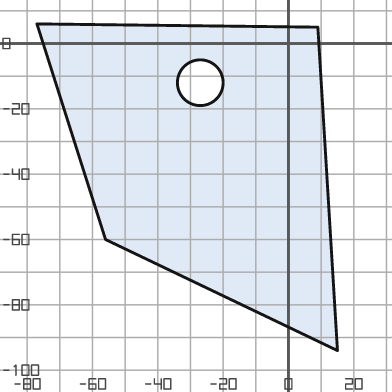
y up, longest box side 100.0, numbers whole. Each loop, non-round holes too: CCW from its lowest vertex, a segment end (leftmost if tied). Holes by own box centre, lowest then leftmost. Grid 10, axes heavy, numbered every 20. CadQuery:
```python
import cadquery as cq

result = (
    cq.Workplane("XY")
    .moveTo(15.0, -94.0)
    .lineTo(9.0, 5.0)
    .lineTo(-77.0, 6.0)
    .lineTo(-56.0, -60.0)
    .close()
    .moveTo(-27.0, -12.0)
    .circle(7.0)
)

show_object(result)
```